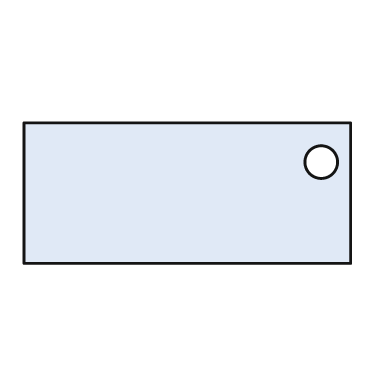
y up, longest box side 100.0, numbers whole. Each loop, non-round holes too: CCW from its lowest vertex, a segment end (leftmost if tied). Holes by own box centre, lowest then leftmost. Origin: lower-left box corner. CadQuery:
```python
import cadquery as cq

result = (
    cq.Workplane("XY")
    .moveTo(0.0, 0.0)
    .lineTo(100.0, 0.0)
    .lineTo(100.0, 43.0)
    .lineTo(0.0, 43.0)
    .close()
    .moveTo(91.0, 31.0)
    .circle(5.0)
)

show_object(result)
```